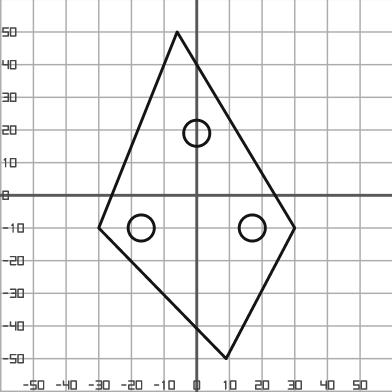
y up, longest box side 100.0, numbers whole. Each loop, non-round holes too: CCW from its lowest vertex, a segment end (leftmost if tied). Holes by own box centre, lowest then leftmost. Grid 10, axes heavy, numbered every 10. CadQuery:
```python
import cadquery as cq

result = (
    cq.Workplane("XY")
    .moveTo(9.0, -50.0)
    .lineTo(30.0, -10.0)
    .lineTo(-6.0, 50.0)
    .lineTo(-30.0, -10.0)
    .close()
    .moveTo(-17.0, -10.0)
    .circle(4.0)
    .moveTo(17.0, -10.0)
    .circle(4.0)
    .moveTo(0.0, 19.0)
    .circle(4.0)
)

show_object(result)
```